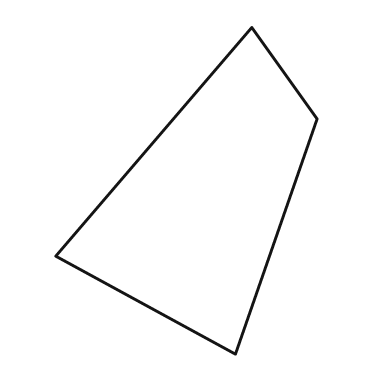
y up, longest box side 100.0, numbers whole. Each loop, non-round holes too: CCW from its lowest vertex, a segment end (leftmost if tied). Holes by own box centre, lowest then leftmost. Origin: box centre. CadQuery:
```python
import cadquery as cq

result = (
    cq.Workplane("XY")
    .moveTo(15.0, -50.0)
    .lineTo(40.0, 22.0)
    .lineTo(20.0, 50.0)
    .lineTo(-40.0, -20.0)
    .close()
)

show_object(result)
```